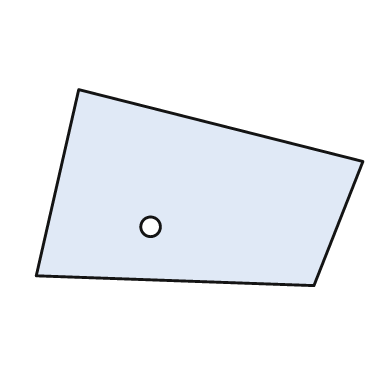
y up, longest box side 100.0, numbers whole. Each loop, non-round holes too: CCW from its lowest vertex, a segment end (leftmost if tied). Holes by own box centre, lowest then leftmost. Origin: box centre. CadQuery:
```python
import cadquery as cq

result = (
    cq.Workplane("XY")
    .moveTo(35.0, -30.0)
    .lineTo(50.0, 8.0)
    .lineTo(-37.0, 30.0)
    .lineTo(-50.0, -27.0)
    .close()
    .moveTo(-15.0, -12.0)
    .circle(3.0)
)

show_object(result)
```